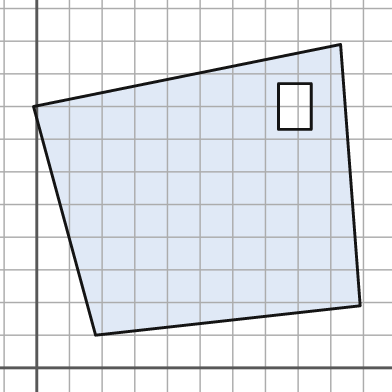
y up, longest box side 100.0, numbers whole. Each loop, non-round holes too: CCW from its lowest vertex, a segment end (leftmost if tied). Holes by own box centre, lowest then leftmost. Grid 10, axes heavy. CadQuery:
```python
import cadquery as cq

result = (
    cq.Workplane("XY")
    .moveTo(18.0, 10.0)
    .lineTo(99.0, 19.0)
    .lineTo(93.0, 99.0)
    .lineTo(-1.0, 80.0)
    .close()
    .moveTo(74.0, 73.0)
    .lineTo(84.0, 73.0)
    .lineTo(84.0, 87.0)
    .lineTo(74.0, 87.0)
    .close()
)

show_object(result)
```